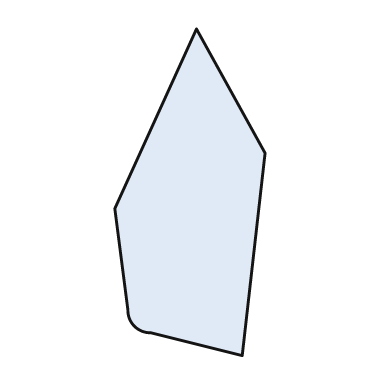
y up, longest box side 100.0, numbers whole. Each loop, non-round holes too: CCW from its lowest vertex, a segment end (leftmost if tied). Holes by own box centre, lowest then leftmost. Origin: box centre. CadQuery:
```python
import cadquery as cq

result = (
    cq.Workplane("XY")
    .moveTo(16.0, -50.0)
    .lineTo(23.0, 12.0)
    .lineTo(2.0, 50.0)
    .lineTo(-23.0, -5.0)
    .lineTo(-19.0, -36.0)
    .threePointArc((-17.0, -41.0), (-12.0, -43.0))
    .close()
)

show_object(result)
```